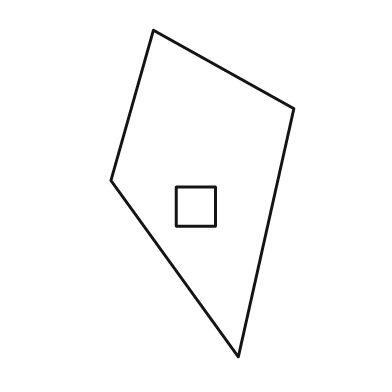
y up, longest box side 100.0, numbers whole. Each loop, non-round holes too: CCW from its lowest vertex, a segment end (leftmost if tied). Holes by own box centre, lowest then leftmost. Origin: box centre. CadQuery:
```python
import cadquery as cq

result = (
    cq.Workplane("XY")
    .moveTo(11.0, -50.0)
    .lineTo(28.0, 26.0)
    .lineTo(-15.0, 50.0)
    .lineTo(-28.0, 4.0)
    .close()
    .moveTo(-8.0, -10.0)
    .lineTo(4.0, -10.0)
    .lineTo(4.0, 2.0)
    .lineTo(-8.0, 2.0)
    .close()
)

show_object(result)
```